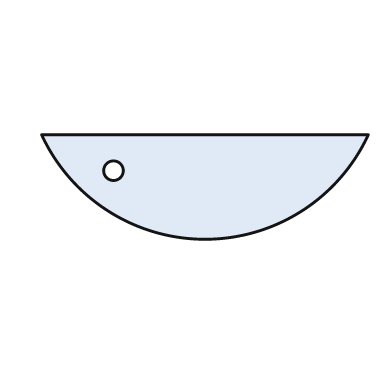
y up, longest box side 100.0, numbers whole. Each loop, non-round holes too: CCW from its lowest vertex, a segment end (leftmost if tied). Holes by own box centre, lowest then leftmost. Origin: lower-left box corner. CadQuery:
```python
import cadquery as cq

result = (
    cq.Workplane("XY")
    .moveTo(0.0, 32.0)
    .threePointArc((50.0, 0.0), (100.0, 32.0))
    .close()
    .moveTo(22.0, 21.0)
    .circle(3.0)
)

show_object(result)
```